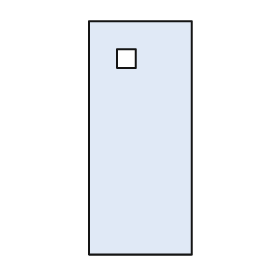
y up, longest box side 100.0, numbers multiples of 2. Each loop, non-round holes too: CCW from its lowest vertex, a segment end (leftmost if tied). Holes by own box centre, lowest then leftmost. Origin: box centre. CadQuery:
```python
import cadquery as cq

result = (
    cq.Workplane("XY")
    .moveTo(-22.0, -50.0)
    .lineTo(22.0, -50.0)
    .lineTo(22.0, 50.0)
    .lineTo(-22.0, 50.0)
    .close()
    .moveTo(-10.0, 30.0)
    .lineTo(-2.0, 30.0)
    .lineTo(-2.0, 38.0)
    .lineTo(-10.0, 38.0)
    .close()
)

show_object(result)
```